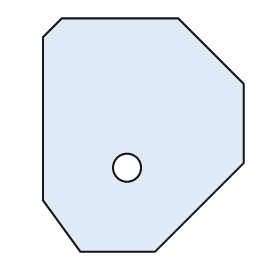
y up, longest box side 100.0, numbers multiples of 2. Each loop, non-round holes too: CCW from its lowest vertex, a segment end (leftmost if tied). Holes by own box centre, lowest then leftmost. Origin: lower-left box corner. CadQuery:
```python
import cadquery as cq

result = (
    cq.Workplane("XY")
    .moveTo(16.0, 0.0)
    .lineTo(48.0, 0.0)
    .lineTo(86.0, 38.0)
    .lineTo(86.0, 72.0)
    .lineTo(58.0, 100.0)
    .lineTo(8.0, 100.0)
    .lineTo(0.0, 92.0)
    .lineTo(0.0, 22.0)
    .close()
    .moveTo(36.0, 36.0)
    .circle(6.0)
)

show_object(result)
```